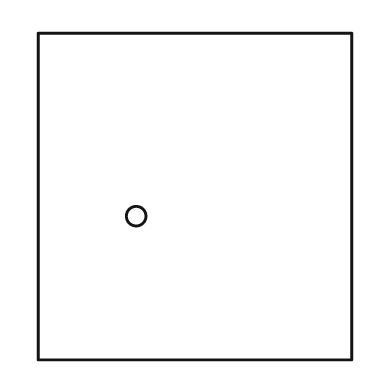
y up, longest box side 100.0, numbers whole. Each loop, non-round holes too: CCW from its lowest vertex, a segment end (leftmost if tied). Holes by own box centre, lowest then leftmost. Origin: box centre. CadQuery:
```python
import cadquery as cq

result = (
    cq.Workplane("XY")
    .moveTo(-48.0, -50.0)
    .lineTo(48.0, -50.0)
    .lineTo(48.0, 50.0)
    .lineTo(-48.0, 50.0)
    .close()
    .moveTo(-18.0, -6.0)
    .circle(3.0)
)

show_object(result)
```